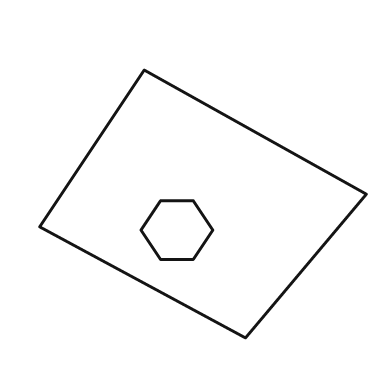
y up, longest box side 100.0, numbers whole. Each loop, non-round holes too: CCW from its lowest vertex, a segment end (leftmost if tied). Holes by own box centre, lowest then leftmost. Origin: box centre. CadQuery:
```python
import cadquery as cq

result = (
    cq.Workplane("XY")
    .moveTo(13.0, -41.0)
    .lineTo(50.0, 3.0)
    .lineTo(-18.0, 41.0)
    .lineTo(-50.0, -7.0)
    .close()
    .moveTo(-13.0, -17.0)
    .lineTo(-3.0, -17.0)
    .lineTo(3.0, -8.0)
    .lineTo(-3.0, 1.0)
    .lineTo(-13.0, 1.0)
    .lineTo(-19.0, -8.0)
    .close()
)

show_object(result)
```